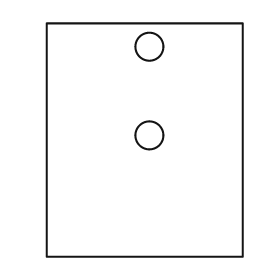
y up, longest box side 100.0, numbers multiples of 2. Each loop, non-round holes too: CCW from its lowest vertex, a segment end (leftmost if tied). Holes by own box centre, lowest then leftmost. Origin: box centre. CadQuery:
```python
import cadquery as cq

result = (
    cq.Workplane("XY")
    .moveTo(-42.0, -50.0)
    .lineTo(42.0, -50.0)
    .lineTo(42.0, 50.0)
    .lineTo(-42.0, 50.0)
    .close()
    .moveTo(2.0, 2.0)
    .circle(6.0)
    .moveTo(2.0, 40.0)
    .circle(6.0)
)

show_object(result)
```